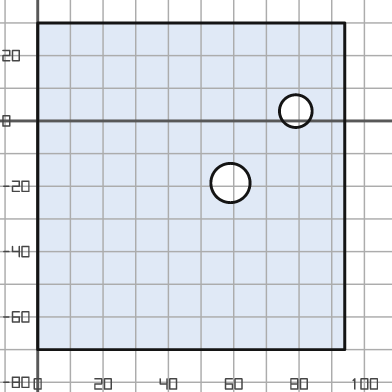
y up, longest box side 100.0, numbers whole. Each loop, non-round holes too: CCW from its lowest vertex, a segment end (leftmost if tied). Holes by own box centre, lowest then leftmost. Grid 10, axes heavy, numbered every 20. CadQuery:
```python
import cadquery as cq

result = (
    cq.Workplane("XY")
    .moveTo(0.0, -70.0)
    .lineTo(94.0, -70.0)
    .lineTo(94.0, 30.0)
    .lineTo(0.0, 30.0)
    .close()
    .moveTo(59.0, -19.0)
    .circle(6.0)
    .moveTo(79.0, 3.0)
    .circle(5.0)
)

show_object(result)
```